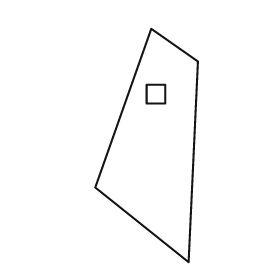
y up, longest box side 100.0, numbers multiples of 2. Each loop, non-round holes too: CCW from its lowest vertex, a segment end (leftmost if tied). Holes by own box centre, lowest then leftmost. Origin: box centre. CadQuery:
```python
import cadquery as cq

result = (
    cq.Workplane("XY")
    .moveTo(18.0, -50.0)
    .lineTo(22.0, 36.0)
    .lineTo(2.0, 50.0)
    .lineTo(-22.0, -18.0)
    .close()
    .moveTo(0.0, 18.0)
    .lineTo(8.0, 18.0)
    .lineTo(8.0, 26.0)
    .lineTo(0.0, 26.0)
    .close()
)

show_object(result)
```